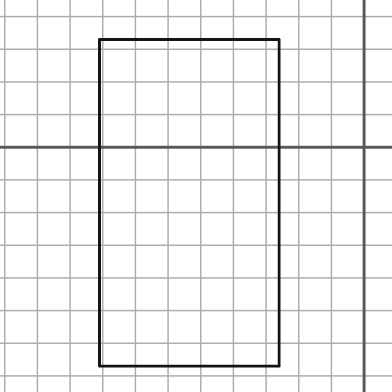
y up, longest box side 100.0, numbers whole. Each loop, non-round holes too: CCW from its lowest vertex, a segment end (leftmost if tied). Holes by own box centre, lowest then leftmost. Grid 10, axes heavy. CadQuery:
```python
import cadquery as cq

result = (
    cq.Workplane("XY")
    .moveTo(-81.0, -67.0)
    .lineTo(-26.0, -67.0)
    .lineTo(-26.0, 33.0)
    .lineTo(-81.0, 33.0)
    .close()
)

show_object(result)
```